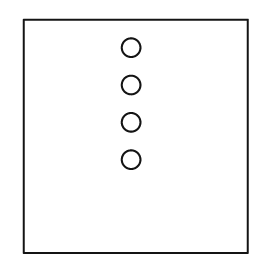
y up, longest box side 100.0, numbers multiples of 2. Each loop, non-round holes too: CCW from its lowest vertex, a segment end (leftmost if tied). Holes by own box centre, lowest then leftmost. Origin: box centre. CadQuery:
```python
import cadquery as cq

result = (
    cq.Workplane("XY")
    .moveTo(-48.0, -50.0)
    .lineTo(48.0, -50.0)
    .lineTo(48.0, 50.0)
    .lineTo(-48.0, 50.0)
    .close()
    .moveTo(-2.0, -10.0)
    .circle(4.0)
    .moveTo(-2.0, 6.0)
    .circle(4.0)
    .moveTo(-2.0, 22.0)
    .circle(4.0)
    .moveTo(-2.0, 38.0)
    .circle(4.0)
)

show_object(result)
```